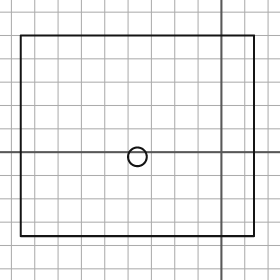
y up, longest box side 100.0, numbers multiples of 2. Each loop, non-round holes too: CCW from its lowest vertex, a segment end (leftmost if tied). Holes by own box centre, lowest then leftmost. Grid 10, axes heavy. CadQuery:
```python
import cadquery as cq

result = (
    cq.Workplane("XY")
    .moveTo(-86.0, -36.0)
    .lineTo(14.0, -36.0)
    .lineTo(14.0, 50.0)
    .lineTo(-86.0, 50.0)
    .close()
    .moveTo(-36.0, -2.0)
    .circle(4.0)
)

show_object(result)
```